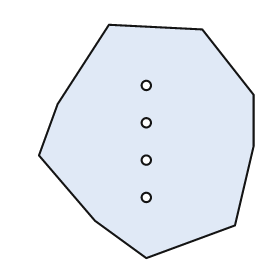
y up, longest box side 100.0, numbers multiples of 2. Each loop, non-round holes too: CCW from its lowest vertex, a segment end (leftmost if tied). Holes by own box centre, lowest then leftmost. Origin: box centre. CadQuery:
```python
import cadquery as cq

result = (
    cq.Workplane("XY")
    .moveTo(0.0, -50.0)
    .lineTo(38.0, -36.0)
    .lineTo(46.0, -2.0)
    .lineTo(46.0, 20.0)
    .lineTo(24.0, 48.0)
    .lineTo(-16.0, 50.0)
    .lineTo(-38.0, 16.0)
    .lineTo(-46.0, -6.0)
    .lineTo(-22.0, -34.0)
    .close()
    .moveTo(0.0, -24.0)
    .circle(2.0)
    .moveTo(0.0, -8.0)
    .circle(2.0)
    .moveTo(0.0, 8.0)
    .circle(2.0)
    .moveTo(0.0, 24.0)
    .circle(2.0)
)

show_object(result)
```